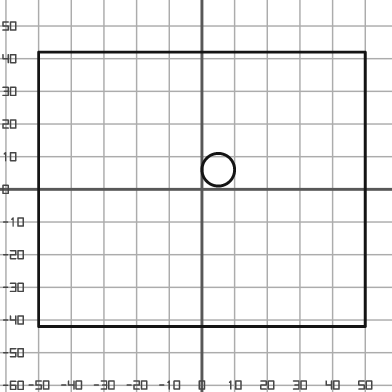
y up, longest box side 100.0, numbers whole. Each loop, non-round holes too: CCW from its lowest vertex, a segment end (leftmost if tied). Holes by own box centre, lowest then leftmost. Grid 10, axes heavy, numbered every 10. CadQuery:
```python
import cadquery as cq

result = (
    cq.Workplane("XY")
    .moveTo(-50.0, -42.0)
    .lineTo(50.0, -42.0)
    .lineTo(50.0, 42.0)
    .lineTo(-50.0, 42.0)
    .close()
    .moveTo(5.0, 6.0)
    .circle(5.0)
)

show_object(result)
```